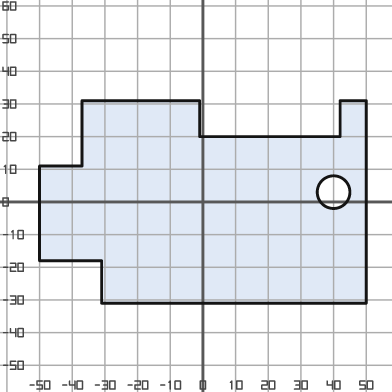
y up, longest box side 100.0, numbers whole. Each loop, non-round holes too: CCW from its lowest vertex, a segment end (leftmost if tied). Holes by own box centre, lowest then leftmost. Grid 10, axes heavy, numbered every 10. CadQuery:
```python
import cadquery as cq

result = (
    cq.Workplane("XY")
    .moveTo(-31.0, -31.0)
    .lineTo(50.0, -31.0)
    .lineTo(50.0, 31.0)
    .lineTo(42.0, 31.0)
    .lineTo(42.0, 20.0)
    .lineTo(-1.0, 20.0)
    .lineTo(-1.0, 31.0)
    .lineTo(-37.0, 31.0)
    .lineTo(-37.0, 11.0)
    .lineTo(-50.0, 11.0)
    .lineTo(-50.0, -18.0)
    .lineTo(-31.0, -18.0)
    .close()
    .moveTo(40.0, 3.0)
    .circle(5.0)
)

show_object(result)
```